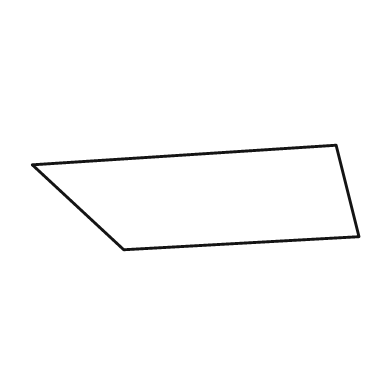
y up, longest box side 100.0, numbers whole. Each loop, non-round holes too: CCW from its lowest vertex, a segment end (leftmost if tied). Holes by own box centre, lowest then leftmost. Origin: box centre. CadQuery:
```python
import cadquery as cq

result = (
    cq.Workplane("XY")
    .moveTo(-22.0, -16.0)
    .lineTo(50.0, -12.0)
    .lineTo(43.0, 16.0)
    .lineTo(-50.0, 10.0)
    .close()
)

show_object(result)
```